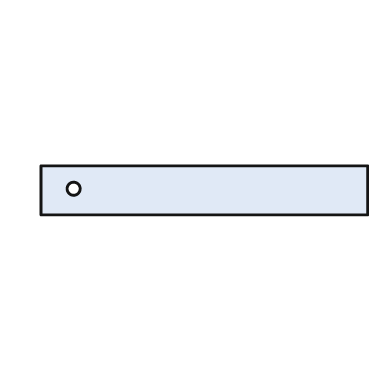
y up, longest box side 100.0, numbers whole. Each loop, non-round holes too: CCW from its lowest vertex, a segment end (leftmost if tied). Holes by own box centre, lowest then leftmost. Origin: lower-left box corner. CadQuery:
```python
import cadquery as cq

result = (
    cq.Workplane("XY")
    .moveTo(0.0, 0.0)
    .lineTo(100.0, 0.0)
    .lineTo(100.0, 15.0)
    .lineTo(0.0, 15.0)
    .close()
    .moveTo(10.0, 8.0)
    .circle(2.0)
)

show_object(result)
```